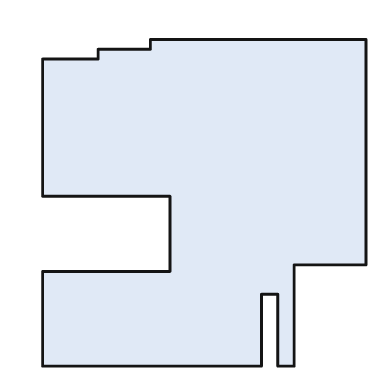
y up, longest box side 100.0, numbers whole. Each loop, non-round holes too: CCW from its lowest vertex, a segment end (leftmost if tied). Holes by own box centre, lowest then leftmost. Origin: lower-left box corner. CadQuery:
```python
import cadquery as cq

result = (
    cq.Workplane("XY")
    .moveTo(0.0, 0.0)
    .lineTo(67.0, 0.0)
    .lineTo(67.0, 22.0)
    .lineTo(72.0, 22.0)
    .lineTo(72.0, 0.0)
    .lineTo(77.0, 0.0)
    .lineTo(77.0, 31.0)
    .lineTo(99.0, 31.0)
    .lineTo(99.0, 100.0)
    .lineTo(33.0, 100.0)
    .lineTo(33.0, 97.0)
    .lineTo(17.0, 97.0)
    .lineTo(17.0, 94.0)
    .lineTo(0.0, 94.0)
    .lineTo(0.0, 52.0)
    .lineTo(39.0, 52.0)
    .lineTo(39.0, 29.0)
    .lineTo(0.0, 29.0)
    .close()
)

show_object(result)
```